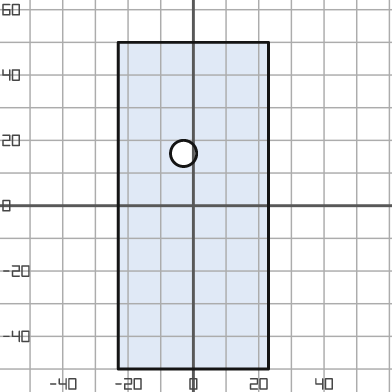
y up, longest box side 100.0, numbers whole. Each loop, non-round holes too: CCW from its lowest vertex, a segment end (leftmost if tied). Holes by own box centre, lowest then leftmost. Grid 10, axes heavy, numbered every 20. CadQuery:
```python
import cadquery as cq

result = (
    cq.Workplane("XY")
    .moveTo(-23.0, -50.0)
    .lineTo(23.0, -50.0)
    .lineTo(23.0, 50.0)
    .lineTo(-23.0, 50.0)
    .close()
    .moveTo(-3.0, 16.0)
    .circle(4.0)
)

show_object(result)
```